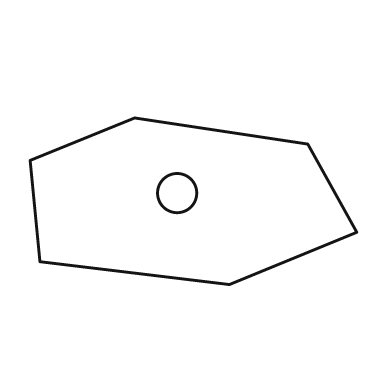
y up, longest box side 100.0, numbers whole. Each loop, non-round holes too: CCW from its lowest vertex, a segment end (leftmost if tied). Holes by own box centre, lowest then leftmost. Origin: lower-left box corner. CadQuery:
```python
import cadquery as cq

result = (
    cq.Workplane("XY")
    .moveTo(61.0, 0.0)
    .lineTo(100.0, 16.0)
    .lineTo(85.0, 43.0)
    .lineTo(32.0, 51.0)
    .lineTo(0.0, 38.0)
    .lineTo(3.0, 7.0)
    .close()
    .moveTo(45.0, 28.0)
    .circle(6.0)
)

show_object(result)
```